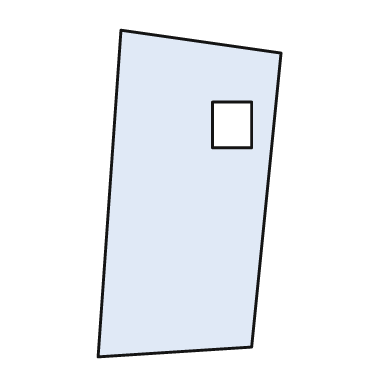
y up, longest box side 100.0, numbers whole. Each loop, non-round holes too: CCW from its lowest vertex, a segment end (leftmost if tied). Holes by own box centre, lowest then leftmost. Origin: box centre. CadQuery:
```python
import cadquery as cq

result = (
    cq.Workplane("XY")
    .moveTo(-28.0, -50.0)
    .lineTo(19.0, -47.0)
    .lineTo(28.0, 43.0)
    .lineTo(-21.0, 50.0)
    .close()
    .moveTo(7.0, 14.0)
    .lineTo(19.0, 14.0)
    .lineTo(19.0, 28.0)
    .lineTo(7.0, 28.0)
    .close()
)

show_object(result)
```